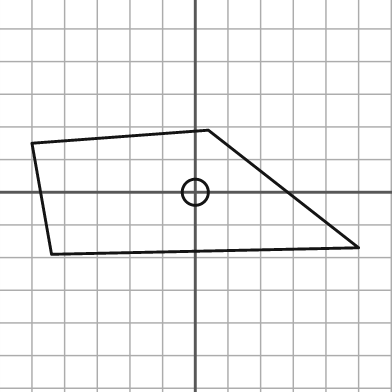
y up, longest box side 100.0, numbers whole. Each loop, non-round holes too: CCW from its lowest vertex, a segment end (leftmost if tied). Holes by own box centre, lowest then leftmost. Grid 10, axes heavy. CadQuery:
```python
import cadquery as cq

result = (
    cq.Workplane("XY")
    .moveTo(-44.0, -19.0)
    .lineTo(50.0, -17.0)
    .lineTo(4.0, 19.0)
    .lineTo(-50.0, 15.0)
    .close()
    .moveTo(0.0, 0.0)
    .circle(4.0)
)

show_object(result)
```